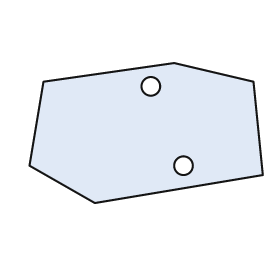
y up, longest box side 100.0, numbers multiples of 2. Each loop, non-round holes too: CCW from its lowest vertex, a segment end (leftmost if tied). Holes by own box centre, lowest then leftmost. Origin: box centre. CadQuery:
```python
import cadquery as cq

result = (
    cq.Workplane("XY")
    .moveTo(-22.0, -30.0)
    .lineTo(50.0, -18.0)
    .lineTo(46.0, 22.0)
    .lineTo(12.0, 30.0)
    .lineTo(-44.0, 22.0)
    .lineTo(-50.0, -14.0)
    .close()
    .moveTo(16.0, -14.0)
    .circle(4.0)
    .moveTo(2.0, 20.0)
    .circle(4.0)
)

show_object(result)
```